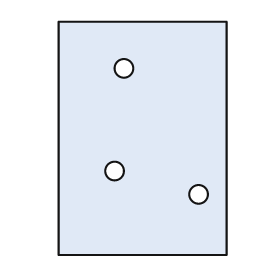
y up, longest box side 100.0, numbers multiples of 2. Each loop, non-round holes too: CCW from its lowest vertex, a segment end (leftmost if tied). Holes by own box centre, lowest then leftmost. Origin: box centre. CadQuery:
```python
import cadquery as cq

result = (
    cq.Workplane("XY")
    .moveTo(-36.0, -50.0)
    .lineTo(36.0, -50.0)
    .lineTo(36.0, 50.0)
    .lineTo(-36.0, 50.0)
    .close()
    .moveTo(24.0, -24.0)
    .circle(4.0)
    .moveTo(-12.0, -14.0)
    .circle(4.0)
    .moveTo(-8.0, 30.0)
    .circle(4.0)
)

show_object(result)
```